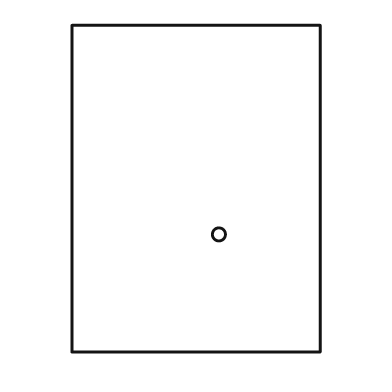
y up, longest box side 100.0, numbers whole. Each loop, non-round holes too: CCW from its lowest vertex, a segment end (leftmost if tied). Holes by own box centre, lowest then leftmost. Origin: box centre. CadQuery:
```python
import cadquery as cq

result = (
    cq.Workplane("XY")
    .moveTo(-38.0, -50.0)
    .lineTo(38.0, -50.0)
    .lineTo(38.0, 50.0)
    .lineTo(-38.0, 50.0)
    .close()
    .moveTo(7.0, -14.0)
    .circle(2.0)
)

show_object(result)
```